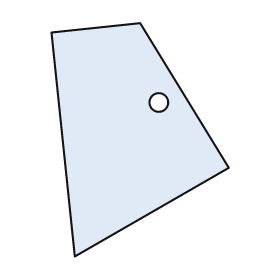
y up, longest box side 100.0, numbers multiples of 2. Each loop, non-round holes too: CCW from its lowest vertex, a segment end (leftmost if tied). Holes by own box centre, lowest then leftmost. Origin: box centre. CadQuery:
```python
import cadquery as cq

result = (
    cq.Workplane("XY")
    .moveTo(-28.0, -50.0)
    .lineTo(38.0, -12.0)
    .lineTo(0.0, 50.0)
    .lineTo(-38.0, 46.0)
    .close()
    .moveTo(8.0, 16.0)
    .circle(4.0)
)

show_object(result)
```